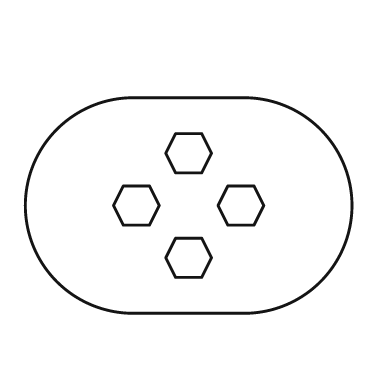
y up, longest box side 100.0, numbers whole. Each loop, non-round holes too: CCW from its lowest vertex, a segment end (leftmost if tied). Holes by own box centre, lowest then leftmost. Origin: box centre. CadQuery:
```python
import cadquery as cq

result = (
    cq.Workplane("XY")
    .moveTo(-17.0, -33.0)
    .lineTo(17.0, -33.0)
    .threePointArc((50.0, 0.0), (17.0, 33.0))
    .lineTo(-17.0, 33.0)
    .threePointArc((-50.0, 0.0), (-17.0, -33.0))
    .close()
    .moveTo(-4.0, -22.0)
    .lineTo(4.0, -22.0)
    .lineTo(7.0, -16.0)
    .lineTo(4.0, -10.0)
    .lineTo(-4.0, -10.0)
    .lineTo(-7.0, -16.0)
    .close()
    .moveTo(-20.0, -6.0)
    .lineTo(-12.0, -6.0)
    .lineTo(-9.0, 0.0)
    .lineTo(-12.0, 6.0)
    .lineTo(-20.0, 6.0)
    .lineTo(-23.0, 0.0)
    .close()
    .moveTo(12.0, -6.0)
    .lineTo(20.0, -6.0)
    .lineTo(23.0, 0.0)
    .lineTo(20.0, 6.0)
    .lineTo(12.0, 6.0)
    .lineTo(9.0, 0.0)
    .close()
    .moveTo(-4.0, 10.0)
    .lineTo(4.0, 10.0)
    .lineTo(7.0, 16.0)
    .lineTo(4.0, 22.0)
    .lineTo(-4.0, 22.0)
    .lineTo(-7.0, 16.0)
    .close()
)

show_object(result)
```